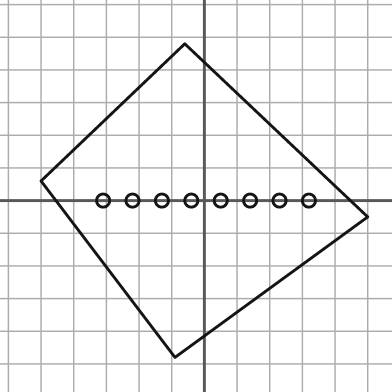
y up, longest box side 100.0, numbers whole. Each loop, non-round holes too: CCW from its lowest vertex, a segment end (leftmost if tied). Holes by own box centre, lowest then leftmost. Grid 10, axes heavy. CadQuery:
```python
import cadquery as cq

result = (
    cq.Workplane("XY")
    .moveTo(-9.0, -48.0)
    .lineTo(50.0, -5.0)
    .lineTo(-6.0, 48.0)
    .lineTo(-50.0, 6.0)
    .close()
    .moveTo(-31.0, 0.0)
    .circle(2.0)
    .moveTo(-22.0, 0.0)
    .circle(2.0)
    .moveTo(-13.0, 0.0)
    .circle(2.0)
    .moveTo(-4.0, 0.0)
    .circle(2.0)
    .moveTo(5.0, 0.0)
    .circle(2.0)
    .moveTo(14.0, 0.0)
    .circle(2.0)
    .moveTo(23.0, 0.0)
    .circle(2.0)
    .moveTo(32.0, 0.0)
    .circle(2.0)
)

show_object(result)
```